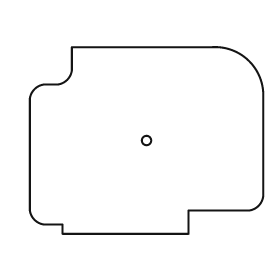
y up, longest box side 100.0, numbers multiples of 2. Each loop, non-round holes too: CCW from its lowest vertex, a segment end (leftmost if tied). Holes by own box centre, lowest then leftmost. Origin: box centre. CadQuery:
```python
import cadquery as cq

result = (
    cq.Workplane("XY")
    .moveTo(-36.0, -40.0)
    .lineTo(18.0, -40.0)
    .lineTo(18.0, -30.0)
    .lineTo(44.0, -30.0)
    .threePointArc((48.0, -28.0), (50.0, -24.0))
    .lineTo(50.0, 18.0)
    .threePointArc((44.0, 34.0), (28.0, 40.0))
    .lineTo(-32.0, 40.0)
    .lineTo(-32.0, 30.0)
    .threePointArc((-34.0, 26.0), (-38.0, 24.0))
    .lineTo(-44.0, 24.0)
    .threePointArc((-48.0, 22.0), (-50.0, 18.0))
    .lineTo(-50.0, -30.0)
    .threePointArc((-48.0, -34.0), (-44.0, -36.0))
    .lineTo(-36.0, -36.0)
    .close()
    .moveTo(0.0, 0.0)
    .circle(2.0)
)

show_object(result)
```